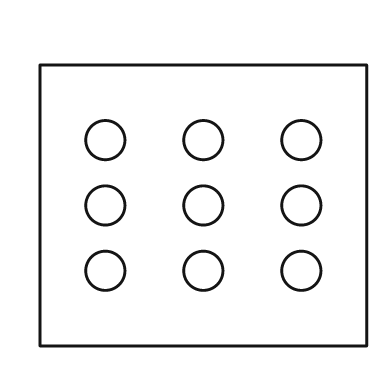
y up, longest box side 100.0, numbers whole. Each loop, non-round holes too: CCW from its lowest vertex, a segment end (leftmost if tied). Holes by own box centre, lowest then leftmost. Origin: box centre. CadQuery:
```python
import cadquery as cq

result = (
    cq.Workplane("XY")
    .moveTo(-50.0, -43.0)
    .lineTo(50.0, -43.0)
    .lineTo(50.0, 43.0)
    .lineTo(-50.0, 43.0)
    .close()
    .moveTo(-30.0, -20.0)
    .circle(6.0)
    .moveTo(0.0, -20.0)
    .circle(6.0)
    .moveTo(30.0, -20.0)
    .circle(6.0)
    .moveTo(-30.0, 0.0)
    .circle(6.0)
    .moveTo(0.0, 0.0)
    .circle(6.0)
    .moveTo(30.0, 0.0)
    .circle(6.0)
    .moveTo(-30.0, 20.0)
    .circle(6.0)
    .moveTo(0.0, 20.0)
    .circle(6.0)
    .moveTo(30.0, 20.0)
    .circle(6.0)
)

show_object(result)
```